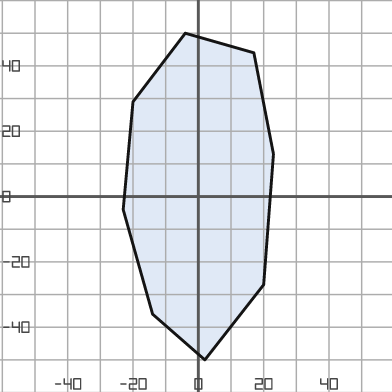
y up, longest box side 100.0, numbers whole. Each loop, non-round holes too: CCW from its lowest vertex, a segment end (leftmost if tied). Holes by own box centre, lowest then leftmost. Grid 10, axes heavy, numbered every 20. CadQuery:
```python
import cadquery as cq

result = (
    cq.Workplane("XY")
    .moveTo(2.0, -50.0)
    .lineTo(20.0, -27.0)
    .lineTo(23.0, 13.0)
    .lineTo(17.0, 44.0)
    .lineTo(-4.0, 50.0)
    .lineTo(-20.0, 29.0)
    .lineTo(-23.0, -4.0)
    .lineTo(-14.0, -36.0)
    .close()
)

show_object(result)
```